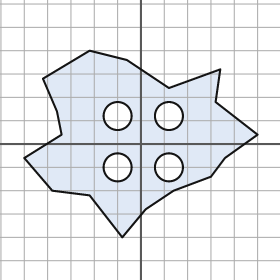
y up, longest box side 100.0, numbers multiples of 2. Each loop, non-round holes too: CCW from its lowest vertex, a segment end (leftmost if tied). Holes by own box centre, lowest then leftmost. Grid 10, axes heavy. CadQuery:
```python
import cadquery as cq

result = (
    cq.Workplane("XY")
    .moveTo(-8.0, -40.0)
    .lineTo(2.0, -28.0)
    .lineTo(14.0, -20.0)
    .lineTo(30.0, -14.0)
    .lineTo(36.0, -6.0)
    .lineTo(50.0, 4.0)
    .lineTo(32.0, 18.0)
    .lineTo(34.0, 32.0)
    .lineTo(12.0, 24.0)
    .lineTo(-6.0, 36.0)
    .lineTo(-22.0, 40.0)
    .lineTo(-42.0, 28.0)
    .lineTo(-36.0, 14.0)
    .lineTo(-34.0, 4.0)
    .lineTo(-50.0, -6.0)
    .lineTo(-38.0, -20.0)
    .lineTo(-22.0, -22.0)
    .close()
    .moveTo(-10.0, -10.0)
    .circle(6.0)
    .moveTo(12.0, -10.0)
    .circle(6.0)
    .moveTo(-10.0, 12.0)
    .circle(6.0)
    .moveTo(12.0, 12.0)
    .circle(6.0)
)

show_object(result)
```